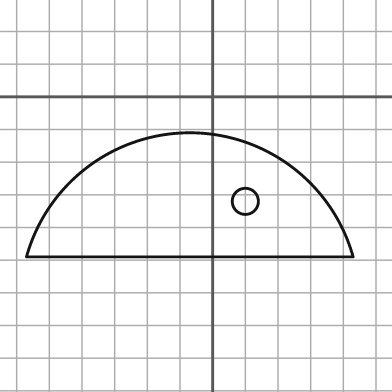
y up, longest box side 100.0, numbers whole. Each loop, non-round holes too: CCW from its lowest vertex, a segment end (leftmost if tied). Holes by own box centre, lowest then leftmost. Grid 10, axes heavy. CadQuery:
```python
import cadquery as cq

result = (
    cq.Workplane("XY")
    .moveTo(-57.0, -49.0)
    .lineTo(43.0, -49.0)
    .threePointArc((-7.0, -11.0), (-57.0, -49.0))
    .close()
    .moveTo(10.0, -32.0)
    .circle(4.0)
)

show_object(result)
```